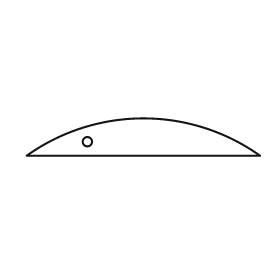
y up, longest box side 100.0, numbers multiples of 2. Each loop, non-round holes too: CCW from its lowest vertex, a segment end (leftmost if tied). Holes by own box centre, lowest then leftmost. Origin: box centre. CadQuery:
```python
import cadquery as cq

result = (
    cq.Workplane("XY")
    .moveTo(-50.0, -8.0)
    .lineTo(50.0, -8.0)
    .threePointArc((0.0, 8.0), (-50.0, -8.0))
    .close()
    .moveTo(-24.0, -2.0)
    .circle(2.0)
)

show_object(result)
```